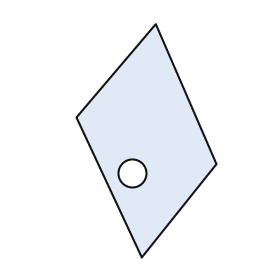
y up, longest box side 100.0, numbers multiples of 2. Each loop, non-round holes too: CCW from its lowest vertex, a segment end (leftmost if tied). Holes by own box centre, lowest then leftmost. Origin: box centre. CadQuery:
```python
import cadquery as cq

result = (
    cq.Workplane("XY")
    .moveTo(-2.0, -50.0)
    .lineTo(30.0, -10.0)
    .lineTo(4.0, 50.0)
    .lineTo(-30.0, 10.0)
    .close()
    .moveTo(-6.0, -14.0)
    .circle(6.0)
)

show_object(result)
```